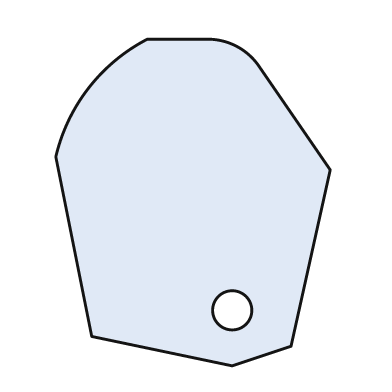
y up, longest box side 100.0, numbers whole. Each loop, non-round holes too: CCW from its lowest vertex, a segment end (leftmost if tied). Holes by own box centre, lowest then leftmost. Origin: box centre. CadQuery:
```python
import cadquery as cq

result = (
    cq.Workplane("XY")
    .moveTo(12.0, -50.0)
    .lineTo(30.0, -44.0)
    .lineTo(42.0, 10.0)
    .lineTo(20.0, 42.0)
    .threePointArc((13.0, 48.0), (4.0, 50.0))
    .lineTo(-14.0, 50.0)
    .threePointArc((-32.0, 35.0), (-42.0, 14.0))
    .lineTo(-31.0, -41.0)
    .close()
    .moveTo(12.0, -33.0)
    .circle(6.0)
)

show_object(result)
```